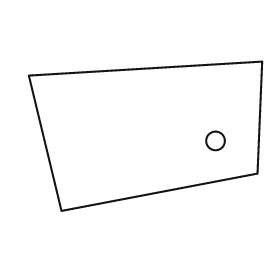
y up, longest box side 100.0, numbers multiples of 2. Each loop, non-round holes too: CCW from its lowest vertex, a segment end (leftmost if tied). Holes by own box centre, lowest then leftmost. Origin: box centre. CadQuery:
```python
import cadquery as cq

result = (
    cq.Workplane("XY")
    .moveTo(-36.0, -32.0)
    .lineTo(48.0, -16.0)
    .lineTo(50.0, 32.0)
    .lineTo(-50.0, 26.0)
    .close()
    .moveTo(30.0, -2.0)
    .circle(4.0)
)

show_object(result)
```